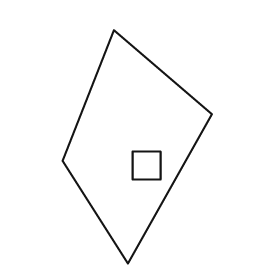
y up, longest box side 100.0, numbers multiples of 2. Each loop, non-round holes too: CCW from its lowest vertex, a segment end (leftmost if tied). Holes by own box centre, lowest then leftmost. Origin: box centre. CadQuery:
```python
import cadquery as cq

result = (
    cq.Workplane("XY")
    .moveTo(-4.0, -50.0)
    .lineTo(32.0, 14.0)
    .lineTo(-10.0, 50.0)
    .lineTo(-32.0, -6.0)
    .close()
    .moveTo(-2.0, -14.0)
    .lineTo(10.0, -14.0)
    .lineTo(10.0, -2.0)
    .lineTo(-2.0, -2.0)
    .close()
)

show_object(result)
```